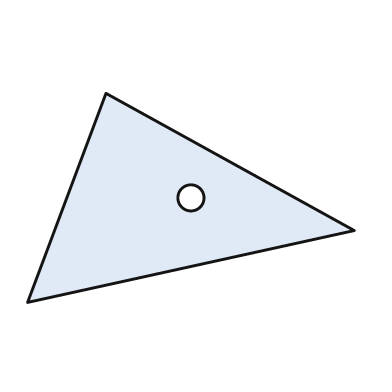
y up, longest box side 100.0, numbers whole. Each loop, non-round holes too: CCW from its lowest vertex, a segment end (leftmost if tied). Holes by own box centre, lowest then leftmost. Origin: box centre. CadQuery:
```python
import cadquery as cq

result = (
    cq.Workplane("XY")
    .moveTo(-50.0, -32.0)
    .lineTo(50.0, -10.0)
    .lineTo(-26.0, 32.0)
    .close()
    .moveTo(0.0, 0.0)
    .circle(4.0)
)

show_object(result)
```